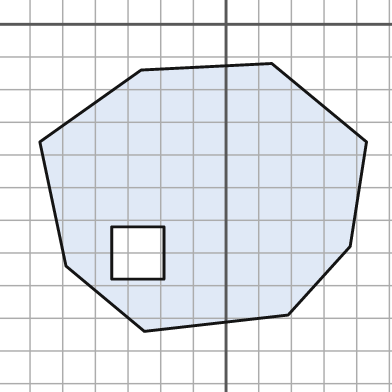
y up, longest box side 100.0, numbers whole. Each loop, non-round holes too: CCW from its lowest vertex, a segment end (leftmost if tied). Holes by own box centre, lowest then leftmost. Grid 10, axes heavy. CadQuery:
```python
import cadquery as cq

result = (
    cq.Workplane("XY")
    .moveTo(-25.0, -94.0)
    .lineTo(19.0, -89.0)
    .lineTo(38.0, -68.0)
    .lineTo(43.0, -36.0)
    .lineTo(14.0, -12.0)
    .lineTo(-26.0, -14.0)
    .lineTo(-57.0, -36.0)
    .lineTo(-49.0, -74.0)
    .close()
    .moveTo(-35.0, -78.0)
    .lineTo(-19.0, -78.0)
    .lineTo(-19.0, -62.0)
    .lineTo(-35.0, -62.0)
    .close()
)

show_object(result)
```